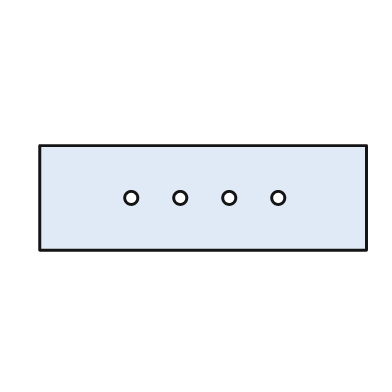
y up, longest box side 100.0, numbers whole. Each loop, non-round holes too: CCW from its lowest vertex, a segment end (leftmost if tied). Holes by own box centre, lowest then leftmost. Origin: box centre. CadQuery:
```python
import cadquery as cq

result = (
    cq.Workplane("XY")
    .moveTo(-50.0, -16.0)
    .lineTo(50.0, -16.0)
    .lineTo(50.0, 16.0)
    .lineTo(-50.0, 16.0)
    .close()
    .moveTo(-22.0, 0.0)
    .circle(2.0)
    .moveTo(-7.0, 0.0)
    .circle(2.0)
    .moveTo(8.0, 0.0)
    .circle(2.0)
    .moveTo(23.0, 0.0)
    .circle(2.0)
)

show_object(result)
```